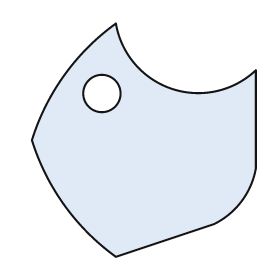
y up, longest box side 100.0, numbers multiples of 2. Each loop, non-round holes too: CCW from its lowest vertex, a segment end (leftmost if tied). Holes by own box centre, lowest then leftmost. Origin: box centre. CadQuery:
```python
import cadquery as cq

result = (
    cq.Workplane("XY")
    .moveTo(-12.0, -50.0)
    .lineTo(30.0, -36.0)
    .threePointArc((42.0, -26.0), (48.0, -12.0))
    .lineTo(48.0, 30.0)
    .threePointArc((12.0, 22.0), (-12.0, 50.0))
    .threePointArc((-34.0, 28.0), (-48.0, 0.0))
    .threePointArc((-34.0, -28.0), (-12.0, -50.0))
    .close()
    .moveTo(-18.0, 20.0)
    .circle(8.0)
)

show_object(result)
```